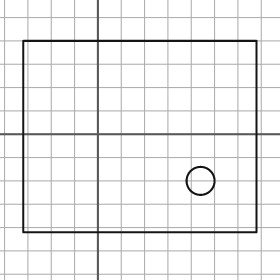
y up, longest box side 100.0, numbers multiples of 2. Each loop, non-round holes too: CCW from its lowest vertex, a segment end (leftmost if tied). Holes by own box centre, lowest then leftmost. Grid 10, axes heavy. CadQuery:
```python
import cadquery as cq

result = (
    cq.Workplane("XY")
    .moveTo(-32.0, -42.0)
    .lineTo(68.0, -42.0)
    .lineTo(68.0, 40.0)
    .lineTo(-32.0, 40.0)
    .close()
    .moveTo(44.0, -20.0)
    .circle(6.0)
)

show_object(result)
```